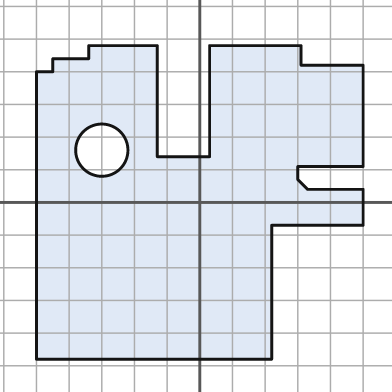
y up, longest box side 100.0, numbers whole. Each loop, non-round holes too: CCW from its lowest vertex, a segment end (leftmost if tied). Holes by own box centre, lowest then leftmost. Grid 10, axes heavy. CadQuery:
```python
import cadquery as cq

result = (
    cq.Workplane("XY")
    .moveTo(-50.0, -48.0)
    .lineTo(22.0, -48.0)
    .lineTo(22.0, -7.0)
    .lineTo(50.0, -7.0)
    .lineTo(50.0, 4.0)
    .lineTo(33.0, 4.0)
    .lineTo(30.0, 7.0)
    .lineTo(30.0, 11.0)
    .lineTo(50.0, 11.0)
    .lineTo(50.0, 42.0)
    .lineTo(31.0, 42.0)
    .lineTo(31.0, 48.0)
    .lineTo(3.0, 48.0)
    .lineTo(3.0, 14.0)
    .lineTo(-13.0, 14.0)
    .lineTo(-13.0, 48.0)
    .lineTo(-34.0, 48.0)
    .lineTo(-34.0, 44.0)
    .lineTo(-45.0, 44.0)
    .lineTo(-45.0, 40.0)
    .lineTo(-50.0, 40.0)
    .close()
    .moveTo(-30.0, 16.0)
    .circle(8.0)
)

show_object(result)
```